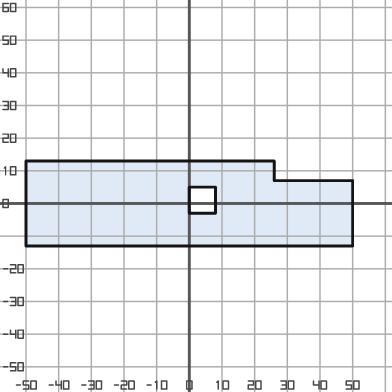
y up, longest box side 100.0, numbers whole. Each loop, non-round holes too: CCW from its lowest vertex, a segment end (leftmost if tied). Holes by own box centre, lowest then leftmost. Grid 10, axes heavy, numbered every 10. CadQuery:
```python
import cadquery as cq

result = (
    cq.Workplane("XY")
    .moveTo(-50.0, -13.0)
    .lineTo(50.0, -13.0)
    .lineTo(50.0, 7.0)
    .lineTo(26.0, 7.0)
    .lineTo(26.0, 13.0)
    .lineTo(-50.0, 13.0)
    .close()
    .moveTo(0.0, -3.0)
    .lineTo(8.0, -3.0)
    .lineTo(8.0, 5.0)
    .lineTo(0.0, 5.0)
    .close()
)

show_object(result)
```